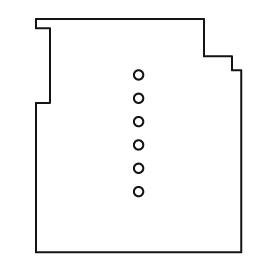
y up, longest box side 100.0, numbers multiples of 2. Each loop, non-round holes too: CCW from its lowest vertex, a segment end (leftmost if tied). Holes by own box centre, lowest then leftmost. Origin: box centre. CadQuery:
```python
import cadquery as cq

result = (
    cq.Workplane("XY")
    .moveTo(-44.0, -50.0)
    .lineTo(44.0, -50.0)
    .lineTo(44.0, 28.0)
    .lineTo(40.0, 28.0)
    .lineTo(40.0, 34.0)
    .lineTo(28.0, 34.0)
    .lineTo(28.0, 50.0)
    .lineTo(-44.0, 50.0)
    .lineTo(-44.0, 46.0)
    .lineTo(-38.0, 46.0)
    .lineTo(-38.0, 14.0)
    .lineTo(-44.0, 14.0)
    .close()
    .moveTo(0.0, -24.0)
    .circle(2.0)
    .moveTo(0.0, -14.0)
    .circle(2.0)
    .moveTo(0.0, -4.0)
    .circle(2.0)
    .moveTo(0.0, 6.0)
    .circle(2.0)
    .moveTo(0.0, 16.0)
    .circle(2.0)
    .moveTo(0.0, 26.0)
    .circle(2.0)
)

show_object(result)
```